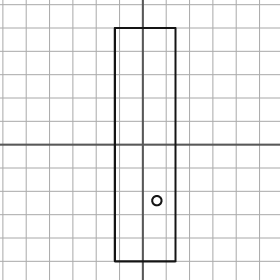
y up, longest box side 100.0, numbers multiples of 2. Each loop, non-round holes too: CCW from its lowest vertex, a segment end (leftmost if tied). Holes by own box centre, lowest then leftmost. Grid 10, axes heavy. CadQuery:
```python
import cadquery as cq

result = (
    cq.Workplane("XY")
    .moveTo(-12.0, -50.0)
    .lineTo(14.0, -50.0)
    .lineTo(14.0, 50.0)
    .lineTo(-12.0, 50.0)
    .close()
    .moveTo(6.0, -24.0)
    .circle(2.0)
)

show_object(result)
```